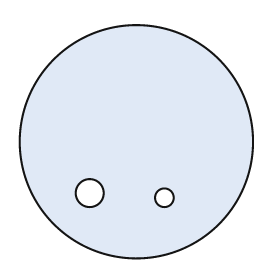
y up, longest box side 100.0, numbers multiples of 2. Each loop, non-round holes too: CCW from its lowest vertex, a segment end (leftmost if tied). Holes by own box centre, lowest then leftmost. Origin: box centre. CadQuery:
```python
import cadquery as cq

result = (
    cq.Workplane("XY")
    .moveTo(0.0, 0.0)
    .circle(50.0)
    .moveTo(12.0, -24.0)
    .circle(4.0)
    .moveTo(-20.0, -22.0)
    .circle(6.0)
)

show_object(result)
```